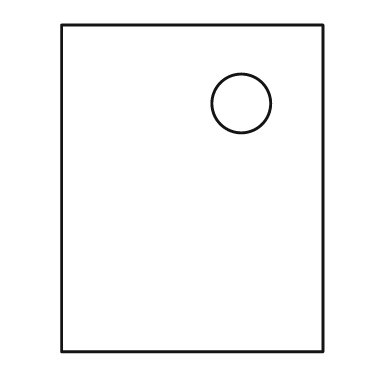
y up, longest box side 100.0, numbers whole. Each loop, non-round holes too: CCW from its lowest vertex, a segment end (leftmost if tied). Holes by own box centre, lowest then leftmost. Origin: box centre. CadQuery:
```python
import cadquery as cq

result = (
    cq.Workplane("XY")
    .moveTo(-40.0, -50.0)
    .lineTo(40.0, -50.0)
    .lineTo(40.0, 50.0)
    .lineTo(-40.0, 50.0)
    .close()
    .moveTo(15.0, 26.0)
    .circle(9.0)
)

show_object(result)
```